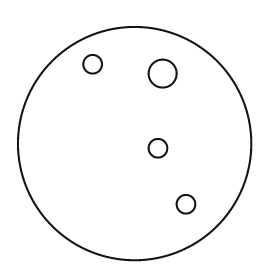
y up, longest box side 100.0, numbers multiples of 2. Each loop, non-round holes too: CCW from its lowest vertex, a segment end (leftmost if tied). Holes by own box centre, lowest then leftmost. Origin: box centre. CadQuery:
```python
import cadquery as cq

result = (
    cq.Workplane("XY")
    .moveTo(0.0, 0.0)
    .circle(50.0)
    .moveTo(22.0, -26.0)
    .circle(4.0)
    .moveTo(10.0, -2.0)
    .circle(4.0)
    .moveTo(12.0, 30.0)
    .circle(6.0)
    .moveTo(-18.0, 34.0)
    .circle(4.0)
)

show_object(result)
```